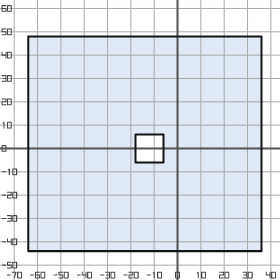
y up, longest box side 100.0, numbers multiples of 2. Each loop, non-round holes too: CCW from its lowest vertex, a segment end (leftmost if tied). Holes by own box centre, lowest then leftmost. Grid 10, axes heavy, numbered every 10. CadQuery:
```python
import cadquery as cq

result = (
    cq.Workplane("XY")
    .moveTo(-64.0, -44.0)
    .lineTo(36.0, -44.0)
    .lineTo(36.0, 48.0)
    .lineTo(-64.0, 48.0)
    .close()
    .moveTo(-18.0, -6.0)
    .lineTo(-6.0, -6.0)
    .lineTo(-6.0, 6.0)
    .lineTo(-18.0, 6.0)
    .close()
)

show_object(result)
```